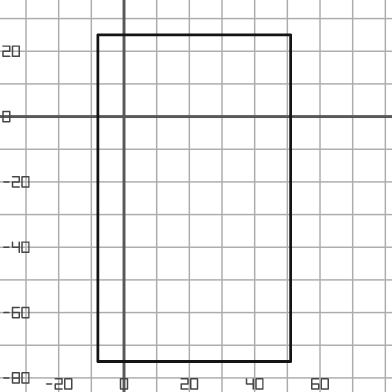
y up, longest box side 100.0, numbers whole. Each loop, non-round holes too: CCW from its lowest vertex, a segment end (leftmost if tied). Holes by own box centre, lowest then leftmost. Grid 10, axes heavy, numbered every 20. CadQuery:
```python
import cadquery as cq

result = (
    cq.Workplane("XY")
    .moveTo(-8.0, -75.0)
    .lineTo(51.0, -75.0)
    .lineTo(51.0, 25.0)
    .lineTo(-8.0, 25.0)
    .close()
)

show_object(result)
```